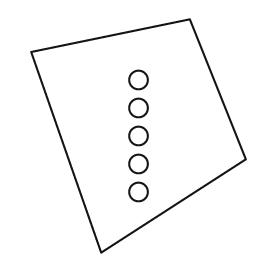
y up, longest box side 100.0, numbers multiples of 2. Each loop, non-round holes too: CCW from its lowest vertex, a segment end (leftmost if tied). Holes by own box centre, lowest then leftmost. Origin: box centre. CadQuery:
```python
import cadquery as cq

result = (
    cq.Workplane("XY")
    .moveTo(-16.0, -50.0)
    .lineTo(46.0, -10.0)
    .lineTo(22.0, 50.0)
    .lineTo(-46.0, 36.0)
    .close()
    .moveTo(0.0, -24.0)
    .circle(4.0)
    .moveTo(0.0, -12.0)
    .circle(4.0)
    .moveTo(0.0, 0.0)
    .circle(4.0)
    .moveTo(0.0, 12.0)
    .circle(4.0)
    .moveTo(0.0, 24.0)
    .circle(4.0)
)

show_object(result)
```